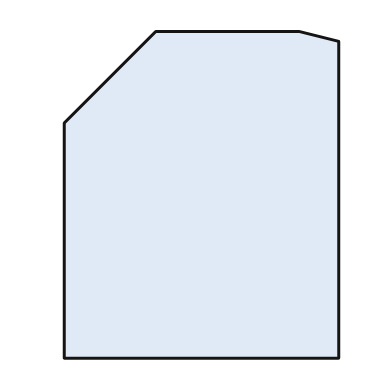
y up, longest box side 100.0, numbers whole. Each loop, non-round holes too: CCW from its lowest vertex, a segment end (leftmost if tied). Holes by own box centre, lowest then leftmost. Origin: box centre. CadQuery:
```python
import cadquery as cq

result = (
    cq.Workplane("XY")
    .moveTo(-42.0, -50.0)
    .lineTo(42.0, -50.0)
    .lineTo(42.0, 47.0)
    .lineTo(30.0, 50.0)
    .lineTo(-14.0, 50.0)
    .lineTo(-42.0, 22.0)
    .close()
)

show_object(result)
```